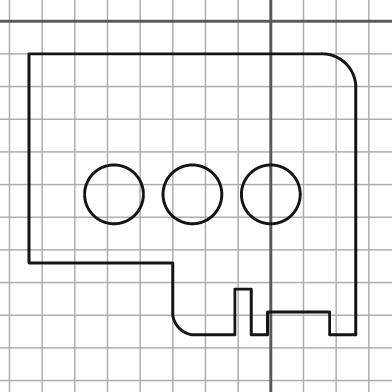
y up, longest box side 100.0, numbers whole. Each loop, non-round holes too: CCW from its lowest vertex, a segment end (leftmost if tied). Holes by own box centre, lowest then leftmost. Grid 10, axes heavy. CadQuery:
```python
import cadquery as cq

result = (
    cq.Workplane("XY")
    .moveTo(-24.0, -96.0)
    .lineTo(-11.0, -96.0)
    .lineTo(-11.0, -82.0)
    .lineTo(-6.0, -82.0)
    .lineTo(-6.0, -96.0)
    .lineTo(-1.0, -96.0)
    .lineTo(-1.0, -89.0)
    .lineTo(18.0, -89.0)
    .lineTo(18.0, -96.0)
    .lineTo(26.0, -96.0)
    .lineTo(26.0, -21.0)
    .threePointArc((23.0, -13.0), (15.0, -10.0))
    .lineTo(-74.0, -10.0)
    .lineTo(-74.0, -74.0)
    .lineTo(-30.0, -74.0)
    .lineTo(-30.0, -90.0)
    .threePointArc((-28.0, -94.0), (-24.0, -96.0))
    .close()
    .moveTo(-48.0, -53.0)
    .circle(9.0)
    .moveTo(-24.0, -53.0)
    .circle(9.0)
    .moveTo(0.0, -53.0)
    .circle(9.0)
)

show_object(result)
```